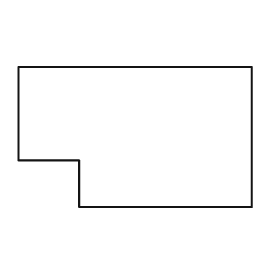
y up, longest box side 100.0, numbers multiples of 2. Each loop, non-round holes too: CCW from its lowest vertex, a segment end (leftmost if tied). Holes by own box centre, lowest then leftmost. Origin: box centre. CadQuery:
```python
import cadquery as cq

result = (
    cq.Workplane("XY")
    .moveTo(-24.0, -30.0)
    .lineTo(50.0, -30.0)
    .lineTo(50.0, 30.0)
    .lineTo(-50.0, 30.0)
    .lineTo(-50.0, -10.0)
    .lineTo(-24.0, -10.0)
    .close()
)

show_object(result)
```